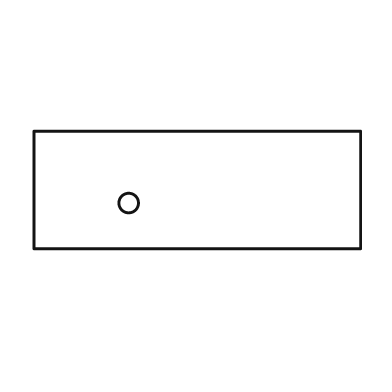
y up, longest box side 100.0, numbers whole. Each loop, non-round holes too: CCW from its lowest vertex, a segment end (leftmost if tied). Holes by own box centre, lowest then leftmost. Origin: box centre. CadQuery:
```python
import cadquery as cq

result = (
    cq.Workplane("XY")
    .moveTo(-50.0, -18.0)
    .lineTo(50.0, -18.0)
    .lineTo(50.0, 18.0)
    .lineTo(-50.0, 18.0)
    .close()
    .moveTo(-21.0, -4.0)
    .circle(3.0)
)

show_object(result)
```